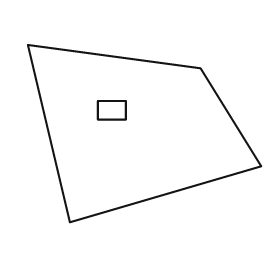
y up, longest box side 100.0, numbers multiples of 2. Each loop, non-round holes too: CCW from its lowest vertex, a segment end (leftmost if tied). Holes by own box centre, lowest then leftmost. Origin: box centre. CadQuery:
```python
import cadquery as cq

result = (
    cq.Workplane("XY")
    .moveTo(-32.0, -38.0)
    .lineTo(50.0, -14.0)
    .lineTo(24.0, 28.0)
    .lineTo(-50.0, 38.0)
    .close()
    .moveTo(-20.0, 6.0)
    .lineTo(-8.0, 6.0)
    .lineTo(-8.0, 14.0)
    .lineTo(-20.0, 14.0)
    .close()
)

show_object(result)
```